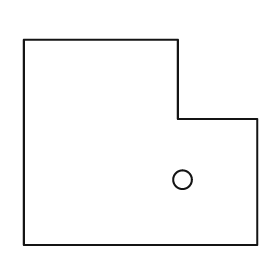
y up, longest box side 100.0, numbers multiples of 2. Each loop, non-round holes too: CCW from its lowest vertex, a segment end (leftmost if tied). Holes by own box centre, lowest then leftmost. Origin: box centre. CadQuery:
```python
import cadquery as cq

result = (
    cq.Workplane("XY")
    .moveTo(-50.0, -44.0)
    .lineTo(50.0, -44.0)
    .lineTo(50.0, 10.0)
    .lineTo(16.0, 10.0)
    .lineTo(16.0, 44.0)
    .lineTo(-50.0, 44.0)
    .close()
    .moveTo(18.0, -16.0)
    .circle(4.0)
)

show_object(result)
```